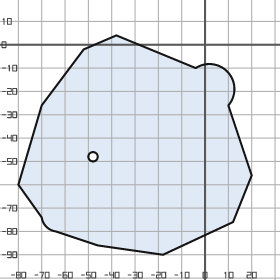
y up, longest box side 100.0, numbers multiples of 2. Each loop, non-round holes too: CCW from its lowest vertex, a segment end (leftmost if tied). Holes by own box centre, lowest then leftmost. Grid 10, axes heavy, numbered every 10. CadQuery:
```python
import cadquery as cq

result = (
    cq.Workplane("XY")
    .moveTo(-18.0, -90.0)
    .lineTo(12.0, -76.0)
    .lineTo(20.0, -56.0)
    .lineTo(10.0, -26.0)
    .threePointArc((10.0, -12.0), (-4.0, -10.0))
    .lineTo(-38.0, 4.0)
    .lineTo(-52.0, -2.0)
    .lineTo(-70.0, -26.0)
    .lineTo(-80.0, -60.0)
    .lineTo(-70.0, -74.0)
    .threePointArc((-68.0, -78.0), (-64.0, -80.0))
    .lineTo(-46.0, -86.0)
    .close()
    .moveTo(-48.0, -48.0)
    .circle(2.0)
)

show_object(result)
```